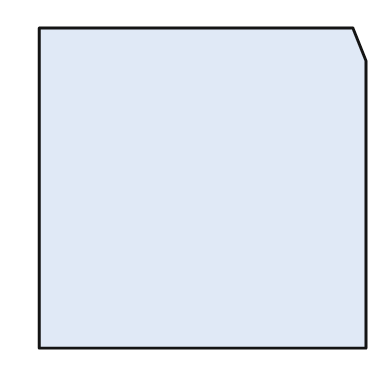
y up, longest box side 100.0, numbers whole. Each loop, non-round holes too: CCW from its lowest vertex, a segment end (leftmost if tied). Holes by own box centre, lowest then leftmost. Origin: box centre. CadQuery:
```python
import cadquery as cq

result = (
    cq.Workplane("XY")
    .moveTo(-50.0, -49.0)
    .lineTo(50.0, -49.0)
    .lineTo(50.0, 39.0)
    .lineTo(46.0, 49.0)
    .lineTo(-50.0, 49.0)
    .close()
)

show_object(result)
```